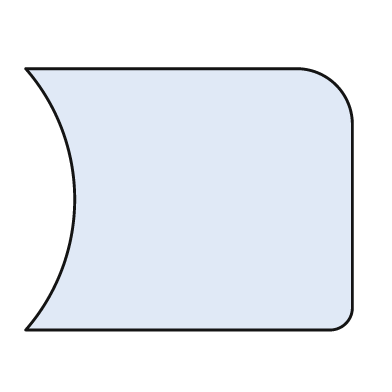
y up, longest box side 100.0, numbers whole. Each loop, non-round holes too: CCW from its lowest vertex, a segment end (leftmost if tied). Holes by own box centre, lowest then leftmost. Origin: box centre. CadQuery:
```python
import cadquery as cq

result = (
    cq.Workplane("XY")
    .moveTo(-50.0, -40.0)
    .lineTo(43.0, -40.0)
    .threePointArc((48.0, -38.0), (50.0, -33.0))
    .lineTo(50.0, 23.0)
    .threePointArc((45.0, 35.0), (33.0, 40.0))
    .lineTo(-50.0, 40.0)
    .threePointArc((-35.0, 0.0), (-50.0, -40.0))
    .close()
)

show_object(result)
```